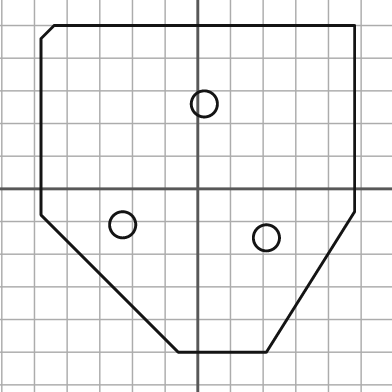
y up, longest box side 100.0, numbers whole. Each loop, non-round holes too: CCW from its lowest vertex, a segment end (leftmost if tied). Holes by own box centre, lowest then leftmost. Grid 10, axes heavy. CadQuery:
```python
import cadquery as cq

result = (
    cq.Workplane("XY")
    .moveTo(-6.0, -50.0)
    .lineTo(21.0, -50.0)
    .lineTo(48.0, -7.0)
    .lineTo(48.0, 50.0)
    .lineTo(-44.0, 50.0)
    .lineTo(-48.0, 46.0)
    .lineTo(-48.0, -8.0)
    .close()
    .moveTo(21.0, -15.0)
    .circle(4.0)
    .moveTo(-23.0, -11.0)
    .circle(4.0)
    .moveTo(2.0, 26.0)
    .circle(4.0)
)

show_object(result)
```